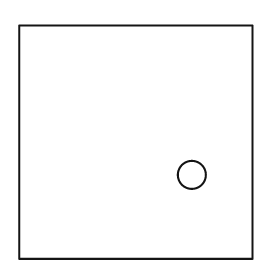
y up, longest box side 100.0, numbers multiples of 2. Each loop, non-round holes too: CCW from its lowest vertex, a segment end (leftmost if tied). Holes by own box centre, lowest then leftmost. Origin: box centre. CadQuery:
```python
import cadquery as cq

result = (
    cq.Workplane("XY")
    .moveTo(-50.0, -50.0)
    .lineTo(50.0, -50.0)
    .lineTo(50.0, 50.0)
    .lineTo(-50.0, 50.0)
    .close()
    .moveTo(24.0, -14.0)
    .circle(6.0)
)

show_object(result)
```